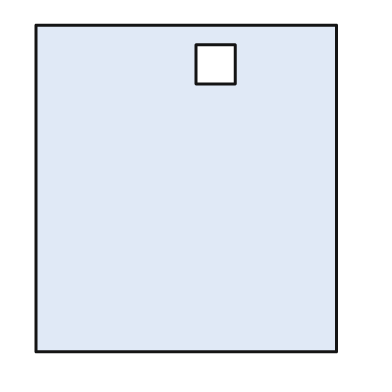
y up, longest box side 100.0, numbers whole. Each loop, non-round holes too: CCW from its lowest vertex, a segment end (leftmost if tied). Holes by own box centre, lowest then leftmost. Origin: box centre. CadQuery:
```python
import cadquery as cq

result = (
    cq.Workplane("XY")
    .moveTo(-46.0, -50.0)
    .lineTo(46.0, -50.0)
    .lineTo(46.0, 50.0)
    .lineTo(-46.0, 50.0)
    .close()
    .moveTo(3.0, 32.0)
    .lineTo(15.0, 32.0)
    .lineTo(15.0, 44.0)
    .lineTo(3.0, 44.0)
    .close()
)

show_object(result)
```